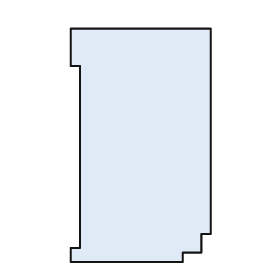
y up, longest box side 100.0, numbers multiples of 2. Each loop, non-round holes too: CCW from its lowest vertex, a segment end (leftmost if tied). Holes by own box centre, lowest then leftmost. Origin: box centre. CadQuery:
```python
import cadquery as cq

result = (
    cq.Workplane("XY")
    .moveTo(-30.0, -50.0)
    .lineTo(18.0, -50.0)
    .lineTo(18.0, -46.0)
    .lineTo(26.0, -46.0)
    .lineTo(26.0, -38.0)
    .lineTo(30.0, -38.0)
    .lineTo(30.0, 50.0)
    .lineTo(-30.0, 50.0)
    .lineTo(-30.0, 34.0)
    .lineTo(-26.0, 34.0)
    .lineTo(-26.0, -44.0)
    .lineTo(-30.0, -44.0)
    .close()
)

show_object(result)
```